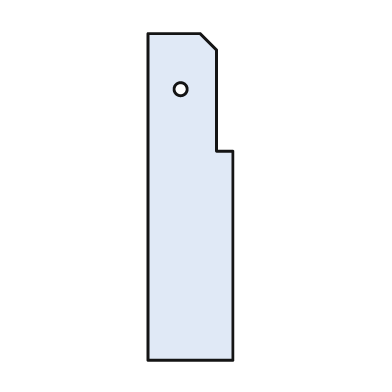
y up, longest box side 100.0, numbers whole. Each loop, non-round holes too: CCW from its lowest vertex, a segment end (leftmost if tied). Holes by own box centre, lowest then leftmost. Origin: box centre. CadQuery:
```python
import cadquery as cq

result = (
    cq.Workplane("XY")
    .moveTo(-13.0, -50.0)
    .lineTo(13.0, -50.0)
    .lineTo(13.0, 14.0)
    .lineTo(8.0, 14.0)
    .lineTo(8.0, 45.0)
    .lineTo(3.0, 50.0)
    .lineTo(-13.0, 50.0)
    .close()
    .moveTo(-3.0, 33.0)
    .circle(2.0)
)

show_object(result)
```